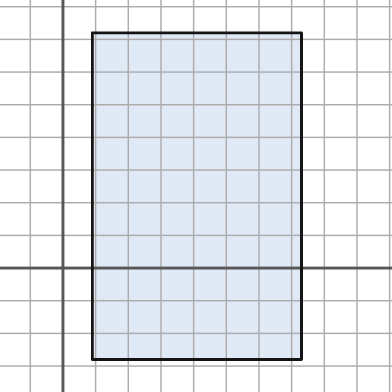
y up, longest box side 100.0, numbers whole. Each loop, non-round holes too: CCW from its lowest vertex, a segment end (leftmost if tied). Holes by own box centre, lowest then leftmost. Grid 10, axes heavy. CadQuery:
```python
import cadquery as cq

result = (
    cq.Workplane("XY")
    .moveTo(9.0, -28.0)
    .lineTo(73.0, -28.0)
    .lineTo(73.0, 72.0)
    .lineTo(9.0, 72.0)
    .close()
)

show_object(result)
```